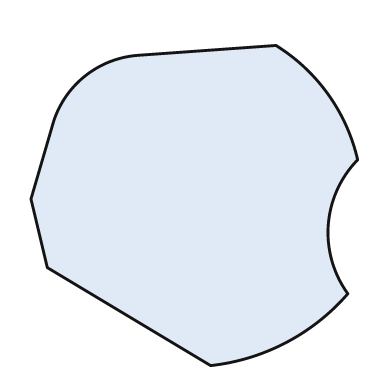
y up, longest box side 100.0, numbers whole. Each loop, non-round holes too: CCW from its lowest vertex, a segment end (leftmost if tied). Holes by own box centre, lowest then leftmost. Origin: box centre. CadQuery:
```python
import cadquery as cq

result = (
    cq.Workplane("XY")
    .moveTo(5.0, -49.0)
    .threePointArc((28.0, -42.0), (47.0, -27.0))
    .threePointArc((41.0, -6.0), (50.0, 14.0))
    .threePointArc((41.0, 34.0), (25.0, 49.0))
    .lineTo(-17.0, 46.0)
    .threePointArc((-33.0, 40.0), (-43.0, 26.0))
    .lineTo(-50.0, 2.0)
    .lineTo(-45.0, -19.0)
    .close()
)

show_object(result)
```